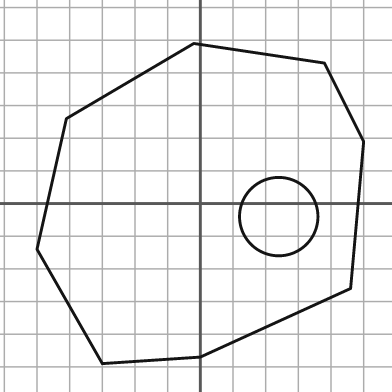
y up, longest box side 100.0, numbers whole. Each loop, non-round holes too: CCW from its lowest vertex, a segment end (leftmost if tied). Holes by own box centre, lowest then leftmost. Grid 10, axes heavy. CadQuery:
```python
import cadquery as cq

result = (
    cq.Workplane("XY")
    .moveTo(-30.0, -49.0)
    .lineTo(0.0, -47.0)
    .lineTo(46.0, -26.0)
    .lineTo(50.0, 19.0)
    .lineTo(38.0, 43.0)
    .lineTo(-2.0, 49.0)
    .lineTo(-41.0, 26.0)
    .lineTo(-50.0, -14.0)
    .close()
    .moveTo(24.0, -4.0)
    .circle(12.0)
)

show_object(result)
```